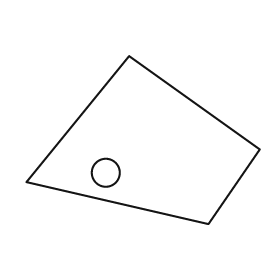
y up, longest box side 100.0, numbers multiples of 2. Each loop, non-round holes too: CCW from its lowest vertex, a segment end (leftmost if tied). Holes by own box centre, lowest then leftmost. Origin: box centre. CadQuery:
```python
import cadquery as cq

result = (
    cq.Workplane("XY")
    .moveTo(28.0, -36.0)
    .lineTo(50.0, -4.0)
    .lineTo(-6.0, 36.0)
    .lineTo(-50.0, -18.0)
    .close()
    .moveTo(-16.0, -14.0)
    .circle(6.0)
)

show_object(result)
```